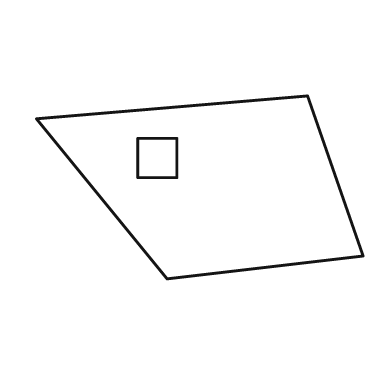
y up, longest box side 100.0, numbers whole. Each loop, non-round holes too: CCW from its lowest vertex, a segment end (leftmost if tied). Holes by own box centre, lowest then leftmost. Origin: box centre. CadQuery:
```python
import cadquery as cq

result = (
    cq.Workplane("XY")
    .moveTo(-10.0, -28.0)
    .lineTo(50.0, -21.0)
    .lineTo(33.0, 28.0)
    .lineTo(-50.0, 21.0)
    .close()
    .moveTo(-19.0, 3.0)
    .lineTo(-7.0, 3.0)
    .lineTo(-7.0, 15.0)
    .lineTo(-19.0, 15.0)
    .close()
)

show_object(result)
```